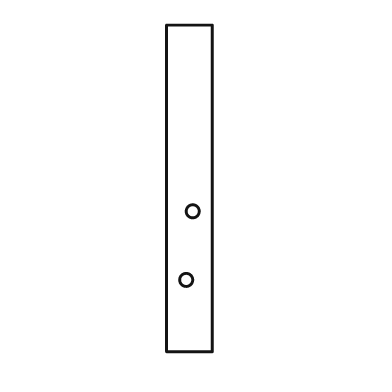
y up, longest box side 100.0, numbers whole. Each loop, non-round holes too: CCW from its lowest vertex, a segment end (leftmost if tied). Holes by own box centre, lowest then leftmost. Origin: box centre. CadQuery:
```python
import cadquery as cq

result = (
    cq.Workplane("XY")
    .moveTo(-7.0, -50.0)
    .lineTo(7.0, -50.0)
    .lineTo(7.0, 50.0)
    .lineTo(-7.0, 50.0)
    .close()
    .moveTo(-1.0, -28.0)
    .circle(2.0)
    .moveTo(1.0, -7.0)
    .circle(2.0)
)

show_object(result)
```